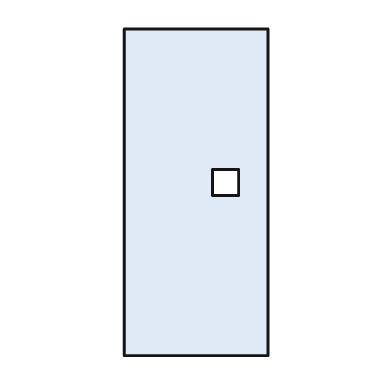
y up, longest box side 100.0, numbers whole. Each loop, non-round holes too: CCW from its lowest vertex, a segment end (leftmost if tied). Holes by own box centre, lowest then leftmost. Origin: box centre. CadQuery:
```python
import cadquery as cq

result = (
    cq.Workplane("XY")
    .moveTo(-22.0, -50.0)
    .lineTo(22.0, -50.0)
    .lineTo(22.0, 50.0)
    .lineTo(-22.0, 50.0)
    .close()
    .moveTo(5.0, -1.0)
    .lineTo(13.0, -1.0)
    .lineTo(13.0, 7.0)
    .lineTo(5.0, 7.0)
    .close()
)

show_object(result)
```